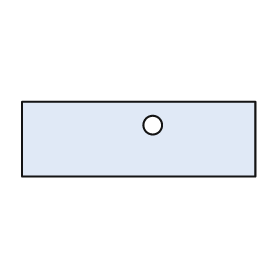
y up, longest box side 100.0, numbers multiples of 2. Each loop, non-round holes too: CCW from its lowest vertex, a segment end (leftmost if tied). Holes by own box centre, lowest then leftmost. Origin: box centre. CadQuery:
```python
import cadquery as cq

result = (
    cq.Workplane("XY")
    .moveTo(-50.0, -16.0)
    .lineTo(50.0, -16.0)
    .lineTo(50.0, 16.0)
    .lineTo(-50.0, 16.0)
    .close()
    .moveTo(6.0, 6.0)
    .circle(4.0)
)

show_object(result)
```